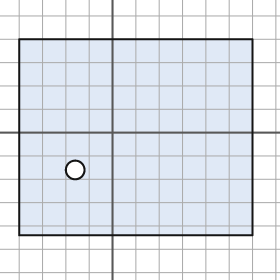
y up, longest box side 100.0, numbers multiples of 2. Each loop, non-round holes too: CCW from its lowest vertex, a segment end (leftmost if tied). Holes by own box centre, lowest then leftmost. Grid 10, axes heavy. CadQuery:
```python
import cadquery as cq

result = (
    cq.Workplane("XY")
    .moveTo(-40.0, -44.0)
    .lineTo(60.0, -44.0)
    .lineTo(60.0, 40.0)
    .lineTo(-40.0, 40.0)
    .close()
    .moveTo(-16.0, -16.0)
    .circle(4.0)
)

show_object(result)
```